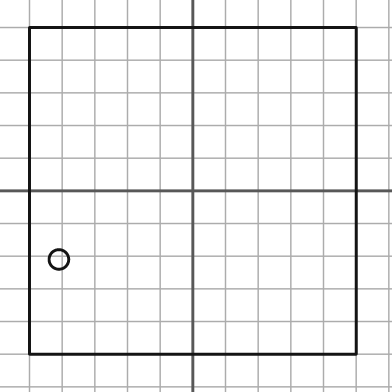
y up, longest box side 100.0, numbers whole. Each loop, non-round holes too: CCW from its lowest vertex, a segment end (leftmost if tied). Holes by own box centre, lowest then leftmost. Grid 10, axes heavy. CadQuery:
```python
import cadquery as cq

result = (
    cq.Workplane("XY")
    .moveTo(-50.0, -50.0)
    .lineTo(50.0, -50.0)
    .lineTo(50.0, 50.0)
    .lineTo(-50.0, 50.0)
    .close()
    .moveTo(-41.0, -21.0)
    .circle(3.0)
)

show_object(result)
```